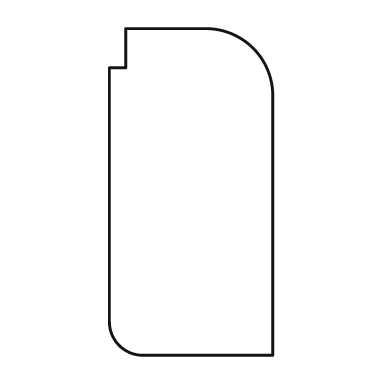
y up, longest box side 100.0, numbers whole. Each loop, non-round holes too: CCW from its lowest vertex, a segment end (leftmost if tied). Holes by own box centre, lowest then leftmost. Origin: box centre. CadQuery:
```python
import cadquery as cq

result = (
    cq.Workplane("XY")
    .moveTo(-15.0, -50.0)
    .lineTo(25.0, -50.0)
    .lineTo(25.0, 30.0)
    .threePointArc((19.0, 44.0), (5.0, 50.0))
    .lineTo(-20.0, 50.0)
    .lineTo(-20.0, 38.0)
    .lineTo(-25.0, 38.0)
    .lineTo(-25.0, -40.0)
    .threePointArc((-22.0, -47.0), (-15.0, -50.0))
    .close()
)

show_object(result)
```